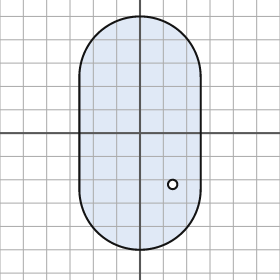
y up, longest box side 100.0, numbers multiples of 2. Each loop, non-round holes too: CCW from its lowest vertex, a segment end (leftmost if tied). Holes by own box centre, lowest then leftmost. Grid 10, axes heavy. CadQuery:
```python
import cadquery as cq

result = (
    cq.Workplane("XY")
    .moveTo(-26.0, -24.0)
    .threePointArc((0.0, -50.0), (26.0, -24.0))
    .lineTo(26.0, 24.0)
    .threePointArc((0.0, 50.0), (-26.0, 24.0))
    .close()
    .moveTo(14.0, -22.0)
    .circle(2.0)
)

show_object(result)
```